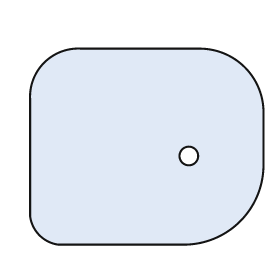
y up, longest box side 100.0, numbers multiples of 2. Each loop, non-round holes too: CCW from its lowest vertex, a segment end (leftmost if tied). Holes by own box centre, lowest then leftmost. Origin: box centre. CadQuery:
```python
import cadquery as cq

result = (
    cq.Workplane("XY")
    .moveTo(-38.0, -42.0)
    .lineTo(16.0, -42.0)
    .threePointArc((40.0, -32.0), (50.0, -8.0))
    .lineTo(50.0, 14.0)
    .threePointArc((42.0, 34.0), (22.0, 42.0))
    .lineTo(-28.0, 42.0)
    .threePointArc((-44.0, 36.0), (-50.0, 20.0))
    .lineTo(-50.0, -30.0)
    .threePointArc((-46.0, -38.0), (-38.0, -42.0))
    .close()
    .moveTo(18.0, -4.0)
    .circle(4.0)
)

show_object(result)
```